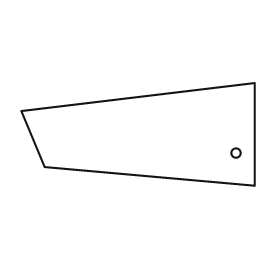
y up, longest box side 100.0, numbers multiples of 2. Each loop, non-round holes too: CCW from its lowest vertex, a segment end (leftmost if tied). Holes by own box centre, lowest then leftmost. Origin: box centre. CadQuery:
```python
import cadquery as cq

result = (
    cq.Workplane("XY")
    .moveTo(50.0, -22.0)
    .lineTo(50.0, 22.0)
    .lineTo(-50.0, 10.0)
    .lineTo(-40.0, -14.0)
    .close()
    .moveTo(42.0, -8.0)
    .circle(2.0)
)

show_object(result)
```